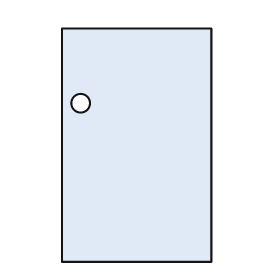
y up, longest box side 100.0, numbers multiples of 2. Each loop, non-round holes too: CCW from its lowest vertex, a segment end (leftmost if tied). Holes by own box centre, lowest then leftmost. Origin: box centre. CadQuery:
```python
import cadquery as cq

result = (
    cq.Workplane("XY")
    .moveTo(-32.0, -50.0)
    .lineTo(32.0, -50.0)
    .lineTo(32.0, 50.0)
    .lineTo(-32.0, 50.0)
    .close()
    .moveTo(-24.0, 18.0)
    .circle(4.0)
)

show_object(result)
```